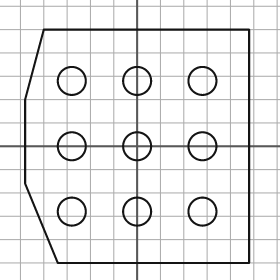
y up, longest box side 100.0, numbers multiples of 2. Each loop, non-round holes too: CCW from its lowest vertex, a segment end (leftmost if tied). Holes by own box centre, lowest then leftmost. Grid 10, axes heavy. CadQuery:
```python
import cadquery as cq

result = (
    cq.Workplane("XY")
    .moveTo(-34.0, -50.0)
    .lineTo(48.0, -50.0)
    .lineTo(48.0, 50.0)
    .lineTo(-40.0, 50.0)
    .lineTo(-48.0, 20.0)
    .lineTo(-48.0, -16.0)
    .close()
    .moveTo(-28.0, -28.0)
    .circle(6.0)
    .moveTo(0.0, -28.0)
    .circle(6.0)
    .moveTo(28.0, -28.0)
    .circle(6.0)
    .moveTo(-28.0, 0.0)
    .circle(6.0)
    .moveTo(0.0, 0.0)
    .circle(6.0)
    .moveTo(28.0, 0.0)
    .circle(6.0)
    .moveTo(-28.0, 28.0)
    .circle(6.0)
    .moveTo(0.0, 28.0)
    .circle(6.0)
    .moveTo(28.0, 28.0)
    .circle(6.0)
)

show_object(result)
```